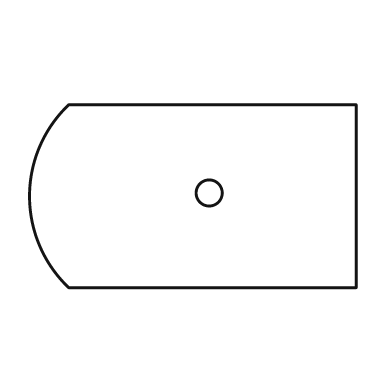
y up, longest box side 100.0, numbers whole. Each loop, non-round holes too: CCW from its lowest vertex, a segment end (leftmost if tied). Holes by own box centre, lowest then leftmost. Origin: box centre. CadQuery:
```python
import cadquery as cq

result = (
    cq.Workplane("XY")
    .moveTo(-38.0, -28.0)
    .lineTo(50.0, -28.0)
    .lineTo(50.0, 28.0)
    .lineTo(-38.0, 28.0)
    .threePointArc((-50.0, 0.0), (-38.0, -28.0))
    .close()
    .moveTo(5.0, 1.0)
    .circle(4.0)
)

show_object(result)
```